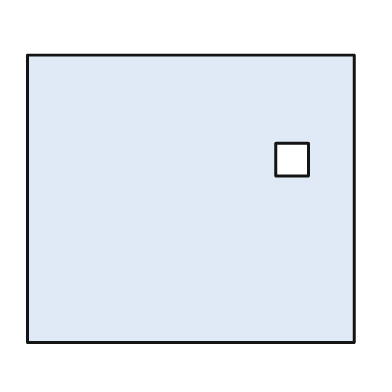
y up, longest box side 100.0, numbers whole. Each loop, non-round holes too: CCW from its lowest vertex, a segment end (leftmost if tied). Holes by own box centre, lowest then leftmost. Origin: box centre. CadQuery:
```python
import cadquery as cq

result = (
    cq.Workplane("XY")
    .moveTo(-50.0, -44.0)
    .lineTo(50.0, -44.0)
    .lineTo(50.0, 44.0)
    .lineTo(-50.0, 44.0)
    .close()
    .moveTo(26.0, 7.0)
    .lineTo(36.0, 7.0)
    .lineTo(36.0, 17.0)
    .lineTo(26.0, 17.0)
    .close()
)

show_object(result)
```